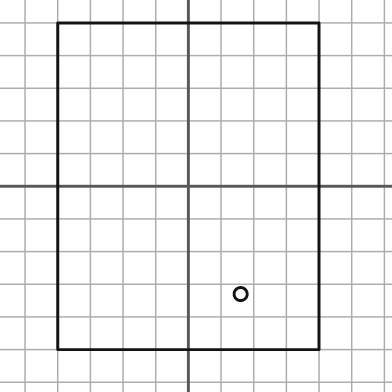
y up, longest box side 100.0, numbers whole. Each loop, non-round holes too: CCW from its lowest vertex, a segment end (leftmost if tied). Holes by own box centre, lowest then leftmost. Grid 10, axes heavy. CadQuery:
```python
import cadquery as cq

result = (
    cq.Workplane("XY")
    .moveTo(-40.0, -50.0)
    .lineTo(40.0, -50.0)
    .lineTo(40.0, 50.0)
    .lineTo(-40.0, 50.0)
    .close()
    .moveTo(16.0, -33.0)
    .circle(2.0)
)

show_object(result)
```